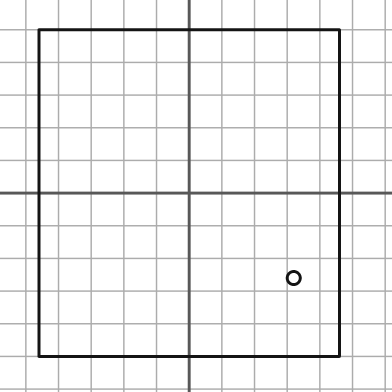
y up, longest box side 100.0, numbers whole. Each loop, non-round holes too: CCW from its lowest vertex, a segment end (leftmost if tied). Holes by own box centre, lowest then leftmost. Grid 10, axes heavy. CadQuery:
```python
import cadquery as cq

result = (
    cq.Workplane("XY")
    .moveTo(-46.0, -50.0)
    .lineTo(46.0, -50.0)
    .lineTo(46.0, 50.0)
    .lineTo(-46.0, 50.0)
    .close()
    .moveTo(32.0, -26.0)
    .circle(2.0)
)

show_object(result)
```